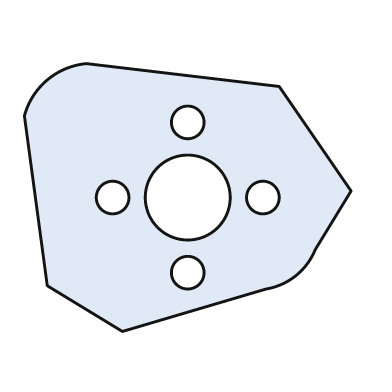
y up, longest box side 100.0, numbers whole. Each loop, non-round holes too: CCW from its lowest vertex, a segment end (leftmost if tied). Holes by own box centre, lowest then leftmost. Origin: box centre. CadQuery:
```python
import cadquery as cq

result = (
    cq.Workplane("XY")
    .moveTo(-20.0, -41.0)
    .lineTo(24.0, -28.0)
    .threePointArc((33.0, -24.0), (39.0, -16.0))
    .lineTo(50.0, 2.0)
    .lineTo(28.0, 34.0)
    .lineTo(-31.0, 41.0)
    .threePointArc((-43.0, 36.0), (-50.0, 25.0))
    .lineTo(-43.0, -27.0)
    .close()
    .moveTo(0.0, -23.0)
    .circle(5.0)
    .moveTo(-23.0, 0.0)
    .circle(5.0)
    .moveTo(0.0, 0.0)
    .circle(13.0)
    .moveTo(23.0, 0.0)
    .circle(5.0)
    .moveTo(0.0, 23.0)
    .circle(5.0)
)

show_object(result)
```